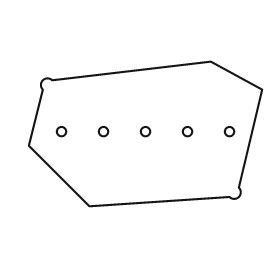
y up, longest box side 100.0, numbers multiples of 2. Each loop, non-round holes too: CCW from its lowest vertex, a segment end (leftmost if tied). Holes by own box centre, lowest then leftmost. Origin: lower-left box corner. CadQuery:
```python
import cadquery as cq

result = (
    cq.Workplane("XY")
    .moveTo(26.0, 0.0)
    .lineTo(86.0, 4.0)
    .threePointArc((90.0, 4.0), (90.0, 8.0))
    .lineTo(100.0, 50.0)
    .lineTo(78.0, 62.0)
    .lineTo(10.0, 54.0)
    .threePointArc((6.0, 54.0), (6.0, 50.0))
    .lineTo(0.0, 26.0)
    .close()
    .moveTo(14.0, 32.0)
    .circle(2.0)
    .moveTo(32.0, 32.0)
    .circle(2.0)
    .moveTo(50.0, 32.0)
    .circle(2.0)
    .moveTo(68.0, 32.0)
    .circle(2.0)
    .moveTo(86.0, 32.0)
    .circle(2.0)
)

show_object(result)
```